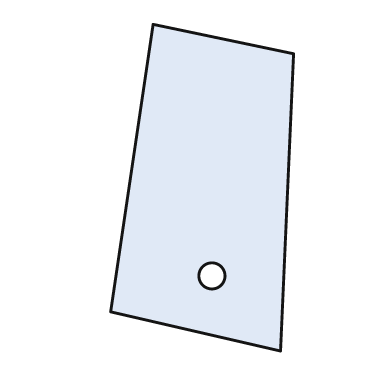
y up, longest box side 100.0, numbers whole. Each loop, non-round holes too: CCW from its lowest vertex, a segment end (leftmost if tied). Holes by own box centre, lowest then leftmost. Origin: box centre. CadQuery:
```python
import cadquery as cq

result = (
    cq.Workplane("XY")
    .moveTo(24.0, -50.0)
    .lineTo(28.0, 41.0)
    .lineTo(-15.0, 50.0)
    .lineTo(-28.0, -38.0)
    .close()
    .moveTo(3.0, -27.0)
    .circle(4.0)
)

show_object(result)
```